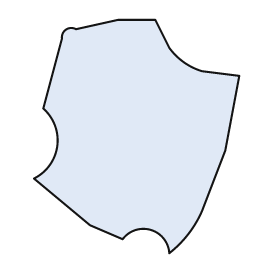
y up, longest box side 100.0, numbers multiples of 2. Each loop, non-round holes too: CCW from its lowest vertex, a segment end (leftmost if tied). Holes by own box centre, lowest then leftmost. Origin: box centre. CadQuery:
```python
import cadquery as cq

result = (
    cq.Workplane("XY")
    .moveTo(14.0, -50.0)
    .threePointArc((22.0, -42.0), (28.0, -32.0))
    .lineTo(38.0, -6.0)
    .lineTo(44.0, 26.0)
    .lineTo(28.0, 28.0)
    .threePointArc((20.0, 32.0), (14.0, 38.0))
    .lineTo(8.0, 50.0)
    .lineTo(-8.0, 50.0)
    .lineTo(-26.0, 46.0)
    .threePointArc((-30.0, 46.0), (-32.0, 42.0))
    .lineTo(-40.0, 12.0)
    .threePointArc((-34.0, -4.0), (-44.0, -18.0))
    .lineTo(-20.0, -38.0)
    .lineTo(-6.0, -44.0)
    .threePointArc((6.0, -40.0), (14.0, -50.0))
    .close()
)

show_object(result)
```